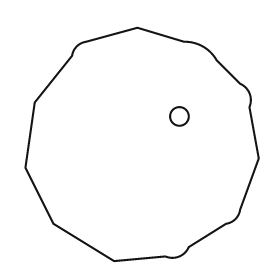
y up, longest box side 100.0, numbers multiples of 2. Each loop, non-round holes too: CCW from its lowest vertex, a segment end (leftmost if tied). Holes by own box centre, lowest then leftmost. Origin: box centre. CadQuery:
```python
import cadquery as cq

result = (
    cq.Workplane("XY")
    .moveTo(-12.0, -50.0)
    .lineTo(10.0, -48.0)
    .threePointArc((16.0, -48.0), (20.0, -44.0))
    .lineTo(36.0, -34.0)
    .threePointArc((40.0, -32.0), (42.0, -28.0))
    .lineTo(50.0, -6.0)
    .lineTo(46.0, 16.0)
    .threePointArc((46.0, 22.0), (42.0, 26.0))
    .lineTo(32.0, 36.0)
    .threePointArc((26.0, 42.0), (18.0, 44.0))
    .lineTo(-2.0, 50.0)
    .lineTo(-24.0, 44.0)
    .threePointArc((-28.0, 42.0), (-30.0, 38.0))
    .lineTo(-46.0, 18.0)
    .lineTo(-50.0, -10.0)
    .lineTo(-38.0, -34.0)
    .close()
    .moveTo(16.0, 12.0)
    .circle(4.0)
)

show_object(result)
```